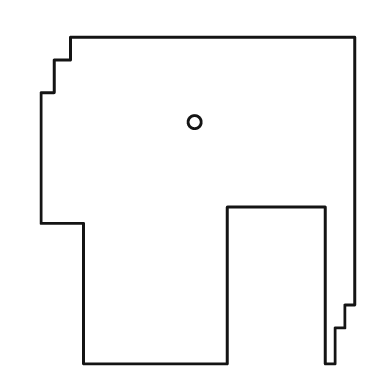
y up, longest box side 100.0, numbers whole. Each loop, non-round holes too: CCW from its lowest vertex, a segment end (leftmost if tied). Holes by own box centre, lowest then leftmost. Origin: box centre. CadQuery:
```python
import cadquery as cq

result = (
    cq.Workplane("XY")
    .moveTo(-35.0, -50.0)
    .lineTo(9.0, -50.0)
    .lineTo(9.0, -2.0)
    .lineTo(39.0, -2.0)
    .lineTo(39.0, -50.0)
    .lineTo(42.0, -50.0)
    .lineTo(42.0, -39.0)
    .lineTo(45.0, -39.0)
    .lineTo(45.0, -32.0)
    .lineTo(48.0, -32.0)
    .lineTo(48.0, 50.0)
    .lineTo(-39.0, 50.0)
    .lineTo(-39.0, 43.0)
    .lineTo(-44.0, 43.0)
    .lineTo(-44.0, 33.0)
    .lineTo(-48.0, 33.0)
    .lineTo(-48.0, -7.0)
    .lineTo(-35.0, -7.0)
    .close()
    .moveTo(-1.0, 24.0)
    .circle(2.0)
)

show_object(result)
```